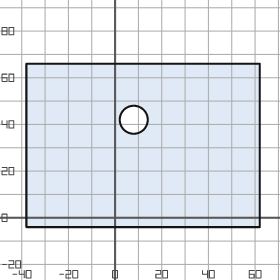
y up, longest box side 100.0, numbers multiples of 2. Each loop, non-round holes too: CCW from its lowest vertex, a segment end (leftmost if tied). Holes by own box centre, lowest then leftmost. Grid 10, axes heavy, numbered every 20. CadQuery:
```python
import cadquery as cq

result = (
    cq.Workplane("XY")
    .moveTo(-38.0, -4.0)
    .lineTo(62.0, -4.0)
    .lineTo(62.0, 66.0)
    .lineTo(-38.0, 66.0)
    .close()
    .moveTo(8.0, 42.0)
    .circle(6.0)
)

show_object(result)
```